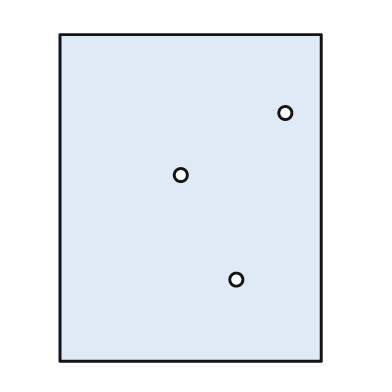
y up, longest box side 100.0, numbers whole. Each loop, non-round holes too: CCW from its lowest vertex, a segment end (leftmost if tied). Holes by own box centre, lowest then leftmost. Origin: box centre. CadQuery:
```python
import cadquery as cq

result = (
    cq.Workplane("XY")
    .moveTo(-40.0, -50.0)
    .lineTo(40.0, -50.0)
    .lineTo(40.0, 50.0)
    .lineTo(-40.0, 50.0)
    .close()
    .moveTo(14.0, -25.0)
    .circle(2.0)
    .moveTo(-3.0, 7.0)
    .circle(2.0)
    .moveTo(29.0, 26.0)
    .circle(2.0)
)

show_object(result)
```